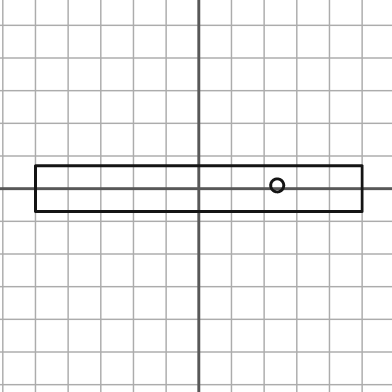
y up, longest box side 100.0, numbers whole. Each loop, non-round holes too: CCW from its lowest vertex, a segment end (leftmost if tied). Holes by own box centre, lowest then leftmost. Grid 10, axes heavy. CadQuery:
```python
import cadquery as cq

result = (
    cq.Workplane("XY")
    .moveTo(-50.0, -7.0)
    .lineTo(50.0, -7.0)
    .lineTo(50.0, 7.0)
    .lineTo(-50.0, 7.0)
    .close()
    .moveTo(24.0, 1.0)
    .circle(2.0)
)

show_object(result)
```